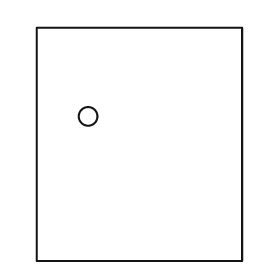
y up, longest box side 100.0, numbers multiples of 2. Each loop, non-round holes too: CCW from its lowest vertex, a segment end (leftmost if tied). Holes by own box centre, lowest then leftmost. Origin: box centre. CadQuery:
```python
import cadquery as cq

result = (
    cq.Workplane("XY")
    .moveTo(-44.0, -50.0)
    .lineTo(44.0, -50.0)
    .lineTo(44.0, 50.0)
    .lineTo(-44.0, 50.0)
    .close()
    .moveTo(-22.0, 12.0)
    .circle(4.0)
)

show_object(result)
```